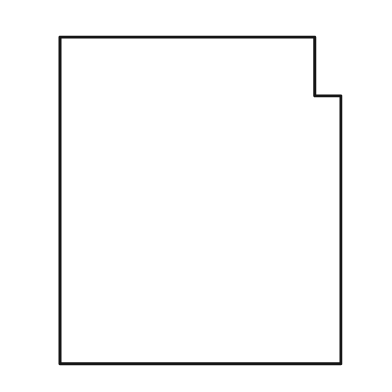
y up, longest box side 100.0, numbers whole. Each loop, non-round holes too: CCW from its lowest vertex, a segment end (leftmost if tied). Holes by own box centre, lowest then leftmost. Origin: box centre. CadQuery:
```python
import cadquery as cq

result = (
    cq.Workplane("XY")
    .moveTo(-43.0, -50.0)
    .lineTo(43.0, -50.0)
    .lineTo(43.0, 32.0)
    .lineTo(35.0, 32.0)
    .lineTo(35.0, 50.0)
    .lineTo(-43.0, 50.0)
    .close()
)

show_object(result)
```